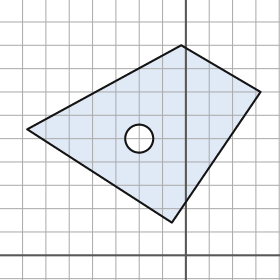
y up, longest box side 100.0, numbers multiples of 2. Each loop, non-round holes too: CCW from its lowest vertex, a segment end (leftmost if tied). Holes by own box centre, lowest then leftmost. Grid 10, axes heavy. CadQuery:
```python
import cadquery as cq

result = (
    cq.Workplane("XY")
    .moveTo(-6.0, 14.0)
    .lineTo(32.0, 70.0)
    .lineTo(-2.0, 90.0)
    .lineTo(-68.0, 54.0)
    .close()
    .moveTo(-20.0, 50.0)
    .circle(6.0)
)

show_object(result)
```